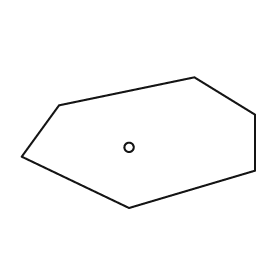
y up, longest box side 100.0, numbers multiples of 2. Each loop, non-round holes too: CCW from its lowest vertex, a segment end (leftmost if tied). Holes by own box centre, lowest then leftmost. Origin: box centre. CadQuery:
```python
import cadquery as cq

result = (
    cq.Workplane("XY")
    .moveTo(-4.0, -28.0)
    .lineTo(50.0, -12.0)
    .lineTo(50.0, 12.0)
    .lineTo(24.0, 28.0)
    .lineTo(-34.0, 16.0)
    .lineTo(-50.0, -6.0)
    .close()
    .moveTo(-4.0, -2.0)
    .circle(2.0)
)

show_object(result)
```